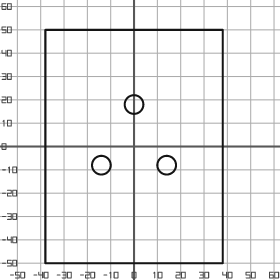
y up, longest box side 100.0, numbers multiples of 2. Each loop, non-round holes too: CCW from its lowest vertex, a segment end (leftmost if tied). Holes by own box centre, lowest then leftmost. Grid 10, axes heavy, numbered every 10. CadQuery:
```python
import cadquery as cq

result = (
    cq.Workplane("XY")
    .moveTo(-38.0, -50.0)
    .lineTo(38.0, -50.0)
    .lineTo(38.0, 50.0)
    .lineTo(-38.0, 50.0)
    .close()
    .moveTo(-14.0, -8.0)
    .circle(4.0)
    .moveTo(14.0, -8.0)
    .circle(4.0)
    .moveTo(0.0, 18.0)
    .circle(4.0)
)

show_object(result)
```